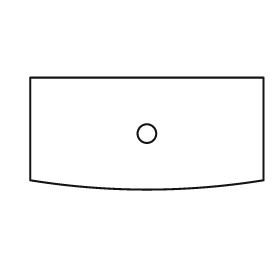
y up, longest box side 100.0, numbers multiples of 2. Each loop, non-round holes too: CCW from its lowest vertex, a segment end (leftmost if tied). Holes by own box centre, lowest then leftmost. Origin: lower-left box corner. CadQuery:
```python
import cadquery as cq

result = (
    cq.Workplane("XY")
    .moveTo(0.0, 4.0)
    .threePointArc((50.0, 0.0), (100.0, 4.0))
    .lineTo(100.0, 48.0)
    .lineTo(0.0, 48.0)
    .close()
    .moveTo(50.0, 24.0)
    .circle(4.0)
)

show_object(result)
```